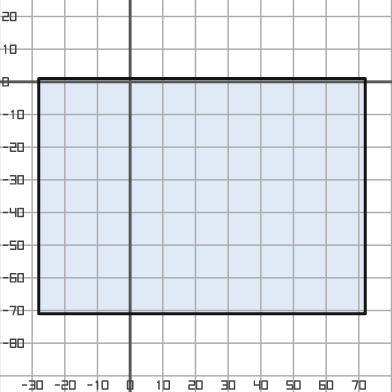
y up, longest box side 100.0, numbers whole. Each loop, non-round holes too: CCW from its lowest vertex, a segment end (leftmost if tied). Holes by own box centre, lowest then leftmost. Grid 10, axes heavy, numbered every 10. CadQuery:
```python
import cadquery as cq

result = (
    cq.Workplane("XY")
    .moveTo(-28.0, -71.0)
    .lineTo(72.0, -71.0)
    .lineTo(72.0, 1.0)
    .lineTo(-28.0, 1.0)
    .close()
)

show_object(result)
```